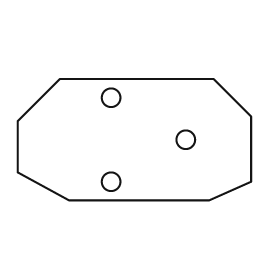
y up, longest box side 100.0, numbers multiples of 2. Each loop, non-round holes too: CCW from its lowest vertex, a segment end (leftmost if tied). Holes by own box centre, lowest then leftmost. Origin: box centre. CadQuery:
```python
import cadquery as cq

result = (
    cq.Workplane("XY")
    .moveTo(-28.0, -26.0)
    .lineTo(32.0, -26.0)
    .lineTo(50.0, -18.0)
    .lineTo(50.0, 10.0)
    .lineTo(34.0, 26.0)
    .lineTo(-32.0, 26.0)
    .lineTo(-50.0, 8.0)
    .lineTo(-50.0, -14.0)
    .close()
    .moveTo(-10.0, -18.0)
    .circle(4.0)
    .moveTo(22.0, 0.0)
    .circle(4.0)
    .moveTo(-10.0, 18.0)
    .circle(4.0)
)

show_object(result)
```